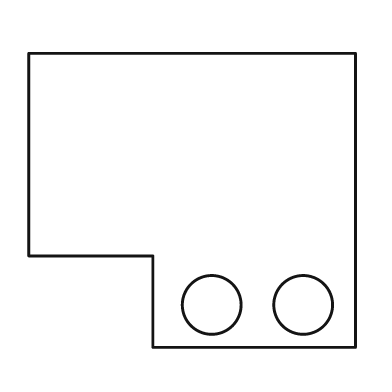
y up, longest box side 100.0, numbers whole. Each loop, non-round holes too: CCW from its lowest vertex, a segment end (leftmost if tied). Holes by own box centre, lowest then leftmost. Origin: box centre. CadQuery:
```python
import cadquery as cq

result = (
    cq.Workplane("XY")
    .moveTo(-12.0, -45.0)
    .lineTo(50.0, -45.0)
    .lineTo(50.0, 45.0)
    .lineTo(-50.0, 45.0)
    .lineTo(-50.0, -17.0)
    .lineTo(-12.0, -17.0)
    .close()
    .moveTo(6.0, -32.0)
    .circle(9.0)
    .moveTo(34.0, -32.0)
    .circle(9.0)
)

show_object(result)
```